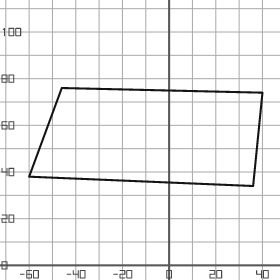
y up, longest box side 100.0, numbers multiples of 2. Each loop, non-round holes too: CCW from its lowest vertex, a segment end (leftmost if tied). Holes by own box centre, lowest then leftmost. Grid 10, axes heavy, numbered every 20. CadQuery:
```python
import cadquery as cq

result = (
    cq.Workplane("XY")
    .moveTo(36.0, 34.0)
    .lineTo(40.0, 74.0)
    .lineTo(-46.0, 76.0)
    .lineTo(-60.0, 38.0)
    .close()
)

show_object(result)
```